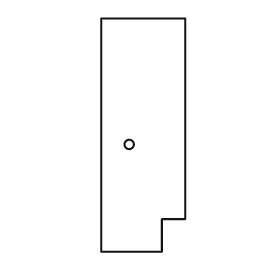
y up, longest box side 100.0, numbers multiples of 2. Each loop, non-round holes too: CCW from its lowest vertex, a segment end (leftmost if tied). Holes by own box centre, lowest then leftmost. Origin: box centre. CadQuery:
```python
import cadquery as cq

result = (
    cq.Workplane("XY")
    .moveTo(-18.0, -50.0)
    .lineTo(8.0, -50.0)
    .lineTo(8.0, -36.0)
    .lineTo(18.0, -36.0)
    .lineTo(18.0, 50.0)
    .lineTo(-18.0, 50.0)
    .close()
    .moveTo(-6.0, -4.0)
    .circle(2.0)
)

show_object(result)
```